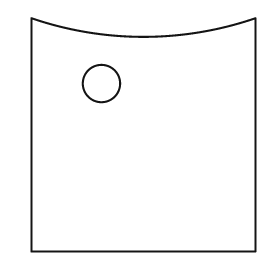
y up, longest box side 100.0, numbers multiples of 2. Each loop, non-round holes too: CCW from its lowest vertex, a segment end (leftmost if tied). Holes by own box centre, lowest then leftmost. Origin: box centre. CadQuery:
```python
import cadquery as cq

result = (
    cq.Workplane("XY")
    .moveTo(-48.0, -50.0)
    .lineTo(48.0, -50.0)
    .lineTo(48.0, 50.0)
    .threePointArc((0.0, 42.0), (-48.0, 50.0))
    .close()
    .moveTo(-18.0, 22.0)
    .circle(8.0)
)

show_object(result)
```